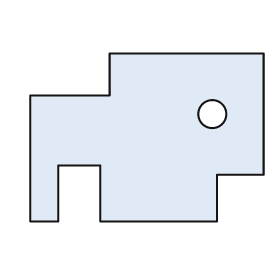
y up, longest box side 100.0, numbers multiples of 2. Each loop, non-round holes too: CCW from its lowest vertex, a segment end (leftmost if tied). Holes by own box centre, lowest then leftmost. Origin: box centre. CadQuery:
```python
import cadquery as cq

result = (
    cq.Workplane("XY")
    .moveTo(-50.0, -36.0)
    .lineTo(-38.0, -36.0)
    .lineTo(-38.0, -12.0)
    .lineTo(-20.0, -12.0)
    .lineTo(-20.0, -36.0)
    .lineTo(30.0, -36.0)
    .lineTo(30.0, -16.0)
    .lineTo(50.0, -16.0)
    .lineTo(50.0, 36.0)
    .lineTo(-16.0, 36.0)
    .lineTo(-16.0, 18.0)
    .lineTo(-50.0, 18.0)
    .close()
    .moveTo(28.0, 10.0)
    .circle(6.0)
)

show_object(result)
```